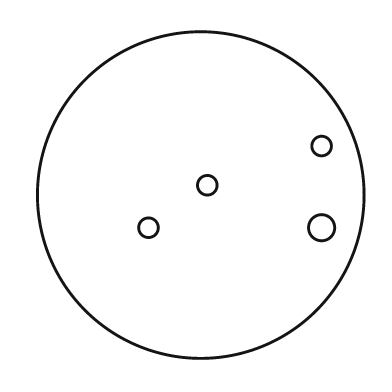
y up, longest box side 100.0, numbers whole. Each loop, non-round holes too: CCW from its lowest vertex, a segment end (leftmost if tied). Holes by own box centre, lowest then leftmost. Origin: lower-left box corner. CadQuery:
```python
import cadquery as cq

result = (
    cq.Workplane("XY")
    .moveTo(50.0, 50.0)
    .circle(50.0)
    .moveTo(34.0, 40.0)
    .circle(3.0)
    .moveTo(87.0, 40.0)
    .circle(4.0)
    .moveTo(52.0, 53.0)
    .circle(3.0)
    .moveTo(87.0, 65.0)
    .circle(3.0)
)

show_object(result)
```